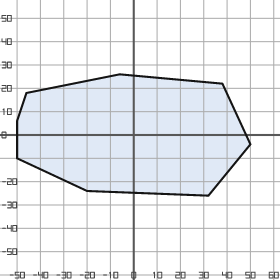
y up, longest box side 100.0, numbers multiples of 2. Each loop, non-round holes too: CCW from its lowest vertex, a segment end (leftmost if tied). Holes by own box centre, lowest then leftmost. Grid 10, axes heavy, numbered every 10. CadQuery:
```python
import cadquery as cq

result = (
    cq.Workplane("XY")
    .moveTo(32.0, -26.0)
    .lineTo(50.0, -4.0)
    .lineTo(38.0, 22.0)
    .lineTo(-6.0, 26.0)
    .lineTo(-46.0, 18.0)
    .lineTo(-50.0, 6.0)
    .lineTo(-50.0, -10.0)
    .lineTo(-20.0, -24.0)
    .close()
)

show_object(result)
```